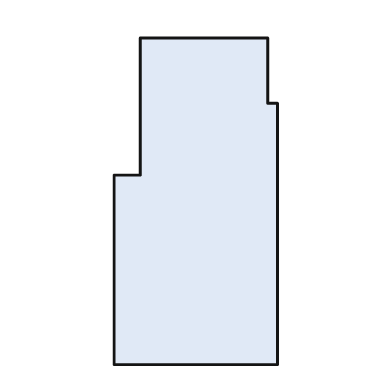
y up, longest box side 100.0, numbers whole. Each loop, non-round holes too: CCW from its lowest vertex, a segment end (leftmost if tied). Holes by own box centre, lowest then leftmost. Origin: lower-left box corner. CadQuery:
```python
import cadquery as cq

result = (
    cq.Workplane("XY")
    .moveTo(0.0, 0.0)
    .lineTo(50.0, 0.0)
    .lineTo(50.0, 80.0)
    .lineTo(47.0, 80.0)
    .lineTo(47.0, 100.0)
    .lineTo(8.0, 100.0)
    .lineTo(8.0, 58.0)
    .lineTo(0.0, 58.0)
    .close()
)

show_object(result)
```